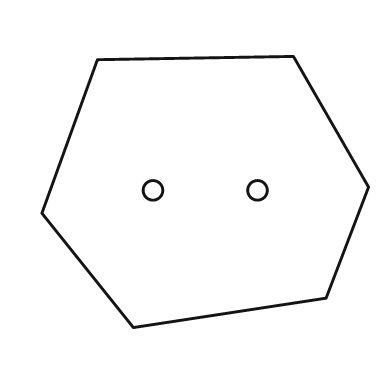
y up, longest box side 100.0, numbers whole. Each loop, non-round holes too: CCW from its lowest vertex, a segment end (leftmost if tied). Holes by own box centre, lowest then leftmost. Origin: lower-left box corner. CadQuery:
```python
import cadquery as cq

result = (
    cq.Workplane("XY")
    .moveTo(28.0, 0.0)
    .lineTo(87.0, 9.0)
    .lineTo(100.0, 43.0)
    .lineTo(77.0, 83.0)
    .lineTo(17.0, 82.0)
    .lineTo(0.0, 35.0)
    .close()
    .moveTo(34.0, 42.0)
    .circle(3.0)
    .moveTo(66.0, 42.0)
    .circle(3.0)
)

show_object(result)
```